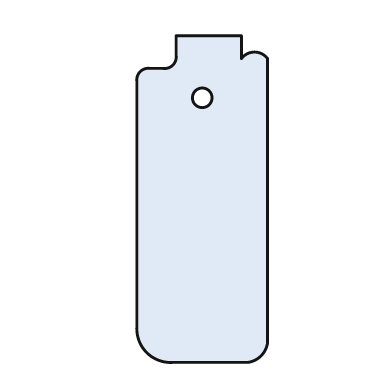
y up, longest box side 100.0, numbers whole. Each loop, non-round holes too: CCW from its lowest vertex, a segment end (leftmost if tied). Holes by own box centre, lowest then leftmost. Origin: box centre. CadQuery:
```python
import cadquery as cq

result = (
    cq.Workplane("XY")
    .moveTo(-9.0, -50.0)
    .lineTo(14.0, -50.0)
    .threePointArc((18.0, -48.0), (20.0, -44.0))
    .lineTo(20.0, 43.0)
    .threePointArc((16.0, 45.0), (12.0, 43.0))
    .lineTo(12.0, 50.0)
    .lineTo(-8.0, 50.0)
    .lineTo(-8.0, 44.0)
    .threePointArc((-9.0, 41.0), (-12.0, 40.0))
    .lineTo(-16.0, 40.0)
    .threePointArc((-19.0, 39.0), (-20.0, 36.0))
    .lineTo(-20.0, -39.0)
    .threePointArc((-17.0, -47.0), (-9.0, -50.0))
    .close()
    .moveTo(0.0, 31.0)
    .circle(3.0)
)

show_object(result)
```